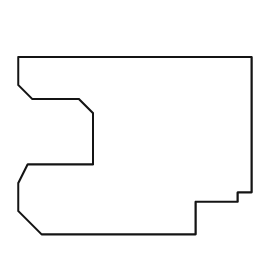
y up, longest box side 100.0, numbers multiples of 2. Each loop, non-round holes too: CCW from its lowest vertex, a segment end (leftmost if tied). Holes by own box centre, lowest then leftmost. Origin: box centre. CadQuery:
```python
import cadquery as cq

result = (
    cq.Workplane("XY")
    .moveTo(-40.0, -38.0)
    .lineTo(26.0, -38.0)
    .lineTo(26.0, -24.0)
    .lineTo(44.0, -24.0)
    .lineTo(44.0, -20.0)
    .lineTo(50.0, -20.0)
    .lineTo(50.0, 38.0)
    .lineTo(-50.0, 38.0)
    .lineTo(-50.0, 26.0)
    .lineTo(-44.0, 20.0)
    .lineTo(-24.0, 20.0)
    .lineTo(-18.0, 14.0)
    .lineTo(-18.0, -8.0)
    .lineTo(-46.0, -8.0)
    .lineTo(-50.0, -16.0)
    .lineTo(-50.0, -28.0)
    .close()
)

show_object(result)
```